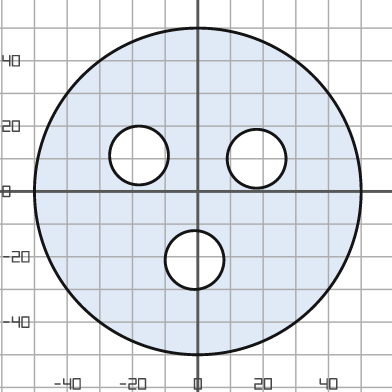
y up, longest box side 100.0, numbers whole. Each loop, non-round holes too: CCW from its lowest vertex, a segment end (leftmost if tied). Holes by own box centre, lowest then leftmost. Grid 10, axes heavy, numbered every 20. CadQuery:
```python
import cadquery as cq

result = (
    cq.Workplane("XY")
    .moveTo(0.0, 0.0)
    .circle(50.0)
    .moveTo(-1.0, -21.0)
    .circle(9.0)
    .moveTo(18.0, 10.0)
    .circle(9.0)
    .moveTo(-18.0, 11.0)
    .circle(9.0)
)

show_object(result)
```